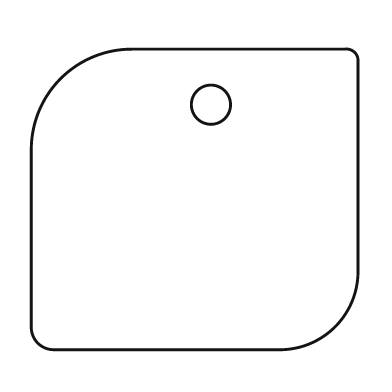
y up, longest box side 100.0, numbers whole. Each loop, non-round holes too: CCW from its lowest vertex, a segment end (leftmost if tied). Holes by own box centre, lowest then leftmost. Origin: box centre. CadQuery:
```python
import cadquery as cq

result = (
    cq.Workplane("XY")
    .moveTo(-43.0, -46.0)
    .lineTo(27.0, -46.0)
    .threePointArc((43.0, -39.0), (50.0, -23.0))
    .lineTo(50.0, 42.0)
    .threePointArc((49.0, 45.0), (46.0, 46.0))
    .lineTo(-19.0, 46.0)
    .threePointArc((-41.0, 37.0), (-50.0, 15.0))
    .lineTo(-50.0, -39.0)
    .threePointArc((-48.0, -44.0), (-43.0, -46.0))
    .close()
    .moveTo(5.0, 29.0)
    .circle(6.0)
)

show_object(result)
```